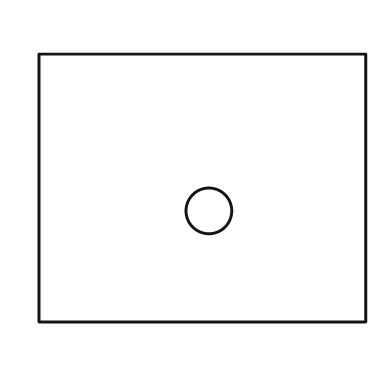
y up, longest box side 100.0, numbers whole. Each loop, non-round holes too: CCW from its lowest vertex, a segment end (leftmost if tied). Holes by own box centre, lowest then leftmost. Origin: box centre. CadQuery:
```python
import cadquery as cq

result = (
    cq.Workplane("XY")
    .moveTo(-50.0, -41.0)
    .lineTo(50.0, -41.0)
    .lineTo(50.0, 41.0)
    .lineTo(-50.0, 41.0)
    .close()
    .moveTo(2.0, -7.0)
    .circle(7.0)
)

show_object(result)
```